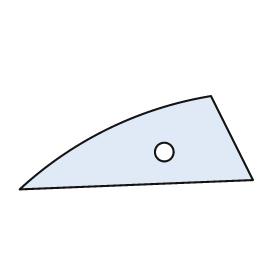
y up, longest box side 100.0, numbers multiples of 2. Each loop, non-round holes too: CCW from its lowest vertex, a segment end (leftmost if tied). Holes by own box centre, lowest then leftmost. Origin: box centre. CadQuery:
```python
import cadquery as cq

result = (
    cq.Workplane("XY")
    .moveTo(-50.0, -20.0)
    .lineTo(50.0, -16.0)
    .lineTo(32.0, 20.0)
    .threePointArc((-12.0, 6.0), (-50.0, -20.0))
    .close()
    .moveTo(12.0, -4.0)
    .circle(4.0)
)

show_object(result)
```